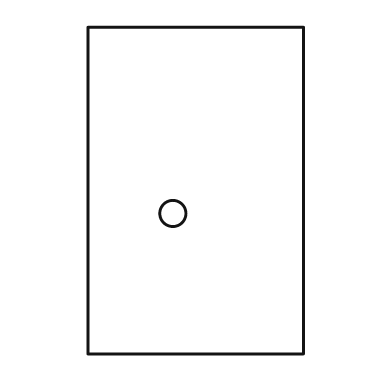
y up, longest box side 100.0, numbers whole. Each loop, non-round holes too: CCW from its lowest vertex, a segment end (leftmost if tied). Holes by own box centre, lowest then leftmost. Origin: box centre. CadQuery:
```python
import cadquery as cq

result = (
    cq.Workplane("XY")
    .moveTo(-33.0, -50.0)
    .lineTo(33.0, -50.0)
    .lineTo(33.0, 50.0)
    .lineTo(-33.0, 50.0)
    .close()
    .moveTo(-7.0, -7.0)
    .circle(4.0)
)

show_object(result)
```